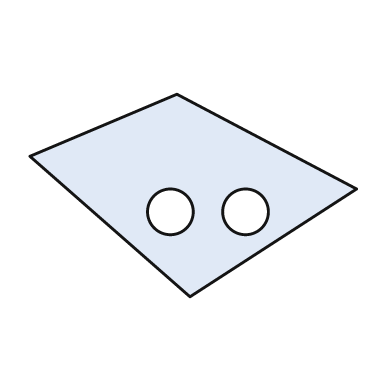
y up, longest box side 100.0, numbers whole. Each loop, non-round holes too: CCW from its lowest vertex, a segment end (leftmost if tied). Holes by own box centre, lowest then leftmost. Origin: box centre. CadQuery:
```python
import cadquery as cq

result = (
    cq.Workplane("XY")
    .moveTo(-1.0, -31.0)
    .lineTo(50.0, 2.0)
    .lineTo(-5.0, 31.0)
    .lineTo(-50.0, 12.0)
    .close()
    .moveTo(-7.0, -5.0)
    .circle(7.0)
    .moveTo(16.0, -5.0)
    .circle(7.0)
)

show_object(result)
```